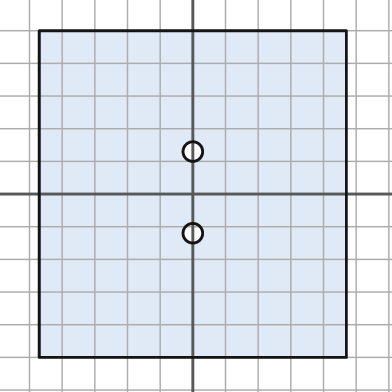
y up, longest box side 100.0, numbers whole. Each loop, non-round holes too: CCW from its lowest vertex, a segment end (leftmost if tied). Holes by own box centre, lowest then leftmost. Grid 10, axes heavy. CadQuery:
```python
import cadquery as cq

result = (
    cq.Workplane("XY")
    .moveTo(-47.0, -50.0)
    .lineTo(47.0, -50.0)
    .lineTo(47.0, 50.0)
    .lineTo(-47.0, 50.0)
    .close()
    .moveTo(0.0, -12.0)
    .circle(3.0)
    .moveTo(0.0, 13.0)
    .circle(3.0)
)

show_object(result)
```